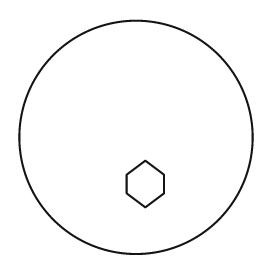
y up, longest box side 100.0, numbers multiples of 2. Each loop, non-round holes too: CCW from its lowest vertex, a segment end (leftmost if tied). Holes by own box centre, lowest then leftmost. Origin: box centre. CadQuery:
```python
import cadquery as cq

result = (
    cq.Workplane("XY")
    .moveTo(0.0, 0.0)
    .circle(50.0)
    .moveTo(4.0, -30.0)
    .lineTo(12.0, -24.0)
    .lineTo(12.0, -16.0)
    .lineTo(4.0, -10.0)
    .lineTo(-4.0, -16.0)
    .lineTo(-4.0, -24.0)
    .close()
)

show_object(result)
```